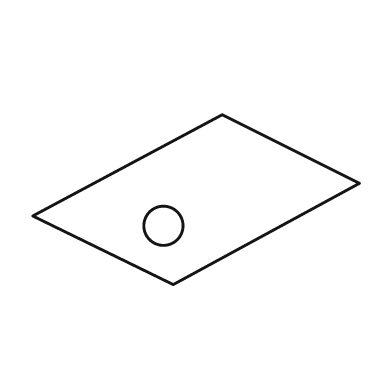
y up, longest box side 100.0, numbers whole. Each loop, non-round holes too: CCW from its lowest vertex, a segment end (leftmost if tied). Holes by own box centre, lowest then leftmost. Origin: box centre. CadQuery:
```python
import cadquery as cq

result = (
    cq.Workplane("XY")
    .moveTo(-7.0, -26.0)
    .lineTo(50.0, 5.0)
    .lineTo(8.0, 26.0)
    .lineTo(-50.0, -5.0)
    .close()
    .moveTo(-10.0, -8.0)
    .circle(6.0)
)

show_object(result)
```